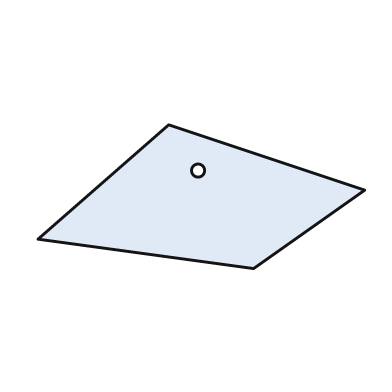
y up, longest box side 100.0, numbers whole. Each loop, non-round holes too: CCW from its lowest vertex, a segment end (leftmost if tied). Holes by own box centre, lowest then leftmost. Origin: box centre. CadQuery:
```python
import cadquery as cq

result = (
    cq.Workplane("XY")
    .moveTo(16.0, -22.0)
    .lineTo(50.0, 2.0)
    .lineTo(-10.0, 22.0)
    .lineTo(-50.0, -13.0)
    .close()
    .moveTo(-1.0, 8.0)
    .circle(2.0)
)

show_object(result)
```